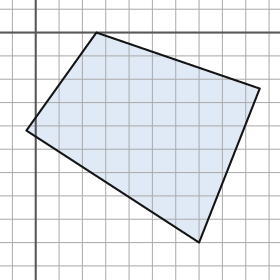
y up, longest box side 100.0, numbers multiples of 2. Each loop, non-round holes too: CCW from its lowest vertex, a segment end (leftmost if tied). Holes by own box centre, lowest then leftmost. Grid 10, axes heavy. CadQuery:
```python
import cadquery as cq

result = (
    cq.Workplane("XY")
    .moveTo(70.0, -90.0)
    .lineTo(96.0, -24.0)
    .lineTo(26.0, 0.0)
    .lineTo(-4.0, -42.0)
    .close()
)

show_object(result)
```